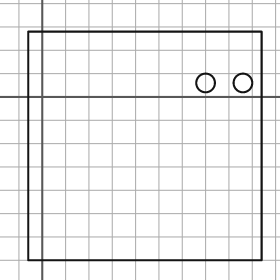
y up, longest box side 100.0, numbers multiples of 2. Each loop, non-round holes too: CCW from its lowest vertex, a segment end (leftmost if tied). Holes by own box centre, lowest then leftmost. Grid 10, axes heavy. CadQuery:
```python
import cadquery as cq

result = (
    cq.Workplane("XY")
    .moveTo(-6.0, -70.0)
    .lineTo(94.0, -70.0)
    .lineTo(94.0, 28.0)
    .lineTo(-6.0, 28.0)
    .close()
    .moveTo(70.0, 6.0)
    .circle(4.0)
    .moveTo(86.0, 6.0)
    .circle(4.0)
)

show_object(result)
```